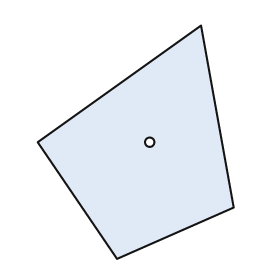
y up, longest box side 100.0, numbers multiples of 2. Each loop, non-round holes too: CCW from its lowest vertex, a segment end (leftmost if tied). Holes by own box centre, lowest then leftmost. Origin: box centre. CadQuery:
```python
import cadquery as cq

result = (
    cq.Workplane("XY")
    .moveTo(-8.0, -50.0)
    .lineTo(42.0, -28.0)
    .lineTo(28.0, 50.0)
    .lineTo(-42.0, 0.0)
    .close()
    .moveTo(6.0, 0.0)
    .circle(2.0)
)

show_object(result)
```